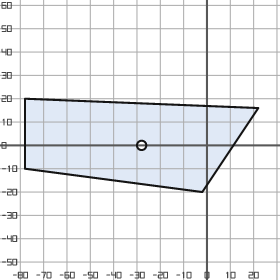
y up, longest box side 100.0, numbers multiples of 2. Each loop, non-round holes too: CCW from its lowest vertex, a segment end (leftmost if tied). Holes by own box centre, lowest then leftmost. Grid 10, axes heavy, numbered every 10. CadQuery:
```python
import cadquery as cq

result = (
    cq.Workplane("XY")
    .moveTo(-2.0, -20.0)
    .lineTo(22.0, 16.0)
    .lineTo(-78.0, 20.0)
    .lineTo(-78.0, -10.0)
    .close()
    .moveTo(-28.0, 0.0)
    .circle(2.0)
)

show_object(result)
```